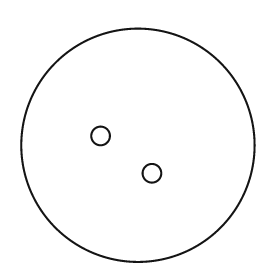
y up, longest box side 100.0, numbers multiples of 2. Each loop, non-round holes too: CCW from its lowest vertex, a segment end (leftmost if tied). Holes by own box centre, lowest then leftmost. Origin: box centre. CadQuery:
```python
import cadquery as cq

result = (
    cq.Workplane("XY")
    .moveTo(0.0, 0.0)
    .circle(50.0)
    .moveTo(6.0, -12.0)
    .circle(4.0)
    .moveTo(-16.0, 4.0)
    .circle(4.0)
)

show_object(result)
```